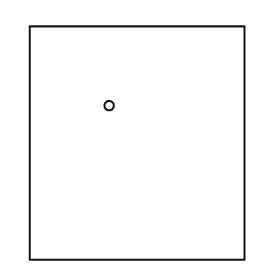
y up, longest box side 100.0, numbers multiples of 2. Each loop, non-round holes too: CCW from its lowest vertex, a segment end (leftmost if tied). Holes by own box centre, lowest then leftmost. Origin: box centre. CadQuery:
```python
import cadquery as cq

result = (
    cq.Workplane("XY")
    .moveTo(-46.0, -50.0)
    .lineTo(46.0, -50.0)
    .lineTo(46.0, 50.0)
    .lineTo(-46.0, 50.0)
    .close()
    .moveTo(-12.0, 16.0)
    .circle(2.0)
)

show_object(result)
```